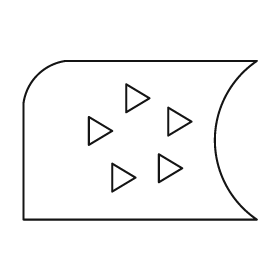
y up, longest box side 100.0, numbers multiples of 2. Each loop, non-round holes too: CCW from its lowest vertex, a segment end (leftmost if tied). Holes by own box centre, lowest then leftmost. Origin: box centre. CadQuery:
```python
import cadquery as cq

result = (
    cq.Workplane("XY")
    .moveTo(-50.0, -34.0)
    .lineTo(50.0, -34.0)
    .threePointArc((32.0, 0.0), (50.0, 34.0))
    .lineTo(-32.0, 34.0)
    .threePointArc((-44.0, 28.0), (-50.0, 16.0))
    .close()
    .moveTo(-12.0, -22.0)
    .lineTo(-2.0, -16.0)
    .lineTo(-12.0, -10.0)
    .close()
    .moveTo(8.0, -18.0)
    .lineTo(18.0, -12.0)
    .lineTo(8.0, -6.0)
    .close()
    .moveTo(-22.0, -2.0)
    .lineTo(-12.0, 4.0)
    .lineTo(-22.0, 10.0)
    .close()
    .moveTo(12.0, 2.0)
    .lineTo(22.0, 8.0)
    .lineTo(12.0, 14.0)
    .close()
    .moveTo(-6.0, 12.0)
    .lineTo(4.0, 18.0)
    .lineTo(-6.0, 24.0)
    .close()
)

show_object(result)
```